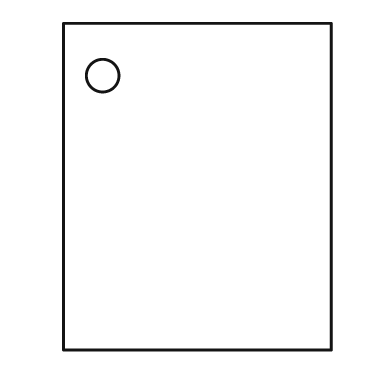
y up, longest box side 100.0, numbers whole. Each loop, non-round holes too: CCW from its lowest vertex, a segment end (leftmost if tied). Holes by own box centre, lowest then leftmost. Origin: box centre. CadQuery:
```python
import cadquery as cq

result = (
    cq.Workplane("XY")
    .moveTo(-41.0, -50.0)
    .lineTo(41.0, -50.0)
    .lineTo(41.0, 50.0)
    .lineTo(-41.0, 50.0)
    .close()
    .moveTo(-29.0, 34.0)
    .circle(5.0)
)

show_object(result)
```